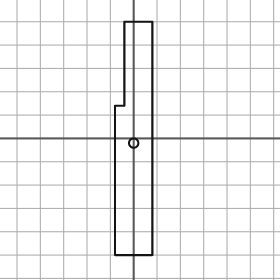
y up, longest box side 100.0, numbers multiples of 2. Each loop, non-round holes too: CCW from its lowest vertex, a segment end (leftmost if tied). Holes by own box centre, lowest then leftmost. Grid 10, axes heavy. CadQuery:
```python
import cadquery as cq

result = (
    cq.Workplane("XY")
    .moveTo(-8.0, -50.0)
    .lineTo(8.0, -50.0)
    .lineTo(8.0, 50.0)
    .lineTo(-4.0, 50.0)
    .lineTo(-4.0, 14.0)
    .lineTo(-8.0, 14.0)
    .close()
    .moveTo(0.0, -2.0)
    .circle(2.0)
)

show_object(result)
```